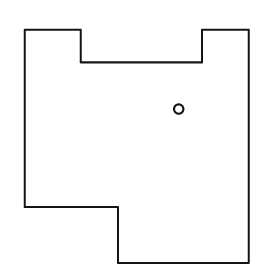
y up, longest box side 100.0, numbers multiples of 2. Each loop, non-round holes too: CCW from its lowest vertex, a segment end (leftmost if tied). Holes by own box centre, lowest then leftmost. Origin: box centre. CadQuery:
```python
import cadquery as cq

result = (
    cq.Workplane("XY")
    .moveTo(-8.0, -50.0)
    .lineTo(48.0, -50.0)
    .lineTo(48.0, 50.0)
    .lineTo(28.0, 50.0)
    .lineTo(28.0, 36.0)
    .lineTo(-24.0, 36.0)
    .lineTo(-24.0, 50.0)
    .lineTo(-48.0, 50.0)
    .lineTo(-48.0, -26.0)
    .lineTo(-8.0, -26.0)
    .close()
    .moveTo(18.0, 16.0)
    .circle(2.0)
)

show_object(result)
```